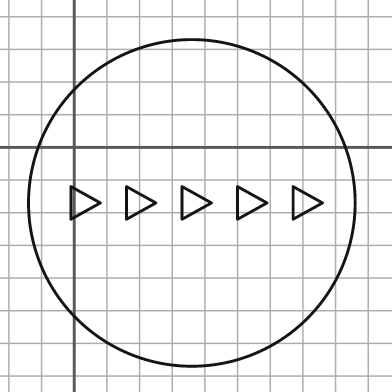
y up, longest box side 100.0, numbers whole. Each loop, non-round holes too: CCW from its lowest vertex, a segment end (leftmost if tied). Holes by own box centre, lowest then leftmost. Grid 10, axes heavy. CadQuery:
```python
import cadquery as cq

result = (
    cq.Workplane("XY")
    .moveTo(36.0, -17.0)
    .circle(50.0)
    .moveTo(-1.0, -22.0)
    .lineTo(8.0, -17.0)
    .lineTo(-1.0, -12.0)
    .close()
    .moveTo(16.0, -22.0)
    .lineTo(25.0, -17.0)
    .lineTo(16.0, -12.0)
    .close()
    .moveTo(33.0, -22.0)
    .lineTo(42.0, -17.0)
    .lineTo(33.0, -12.0)
    .close()
    .moveTo(50.0, -22.0)
    .lineTo(59.0, -17.0)
    .lineTo(50.0, -12.0)
    .close()
    .moveTo(67.0, -22.0)
    .lineTo(76.0, -17.0)
    .lineTo(67.0, -12.0)
    .close()
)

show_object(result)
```